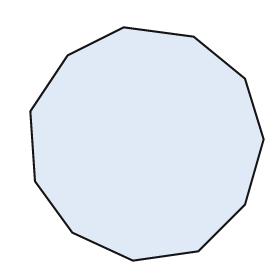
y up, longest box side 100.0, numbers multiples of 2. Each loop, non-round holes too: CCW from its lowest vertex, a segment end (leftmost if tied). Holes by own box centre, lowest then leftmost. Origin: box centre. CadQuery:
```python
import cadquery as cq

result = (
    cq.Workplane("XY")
    .moveTo(-6.0, -50.0)
    .lineTo(22.0, -46.0)
    .lineTo(42.0, -26.0)
    .lineTo(50.0, 2.0)
    .lineTo(42.0, 28.0)
    .lineTo(20.0, 46.0)
    .lineTo(-10.0, 50.0)
    .lineTo(-34.0, 38.0)
    .lineTo(-50.0, 14.0)
    .lineTo(-48.0, -16.0)
    .lineTo(-32.0, -38.0)
    .close()
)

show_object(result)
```